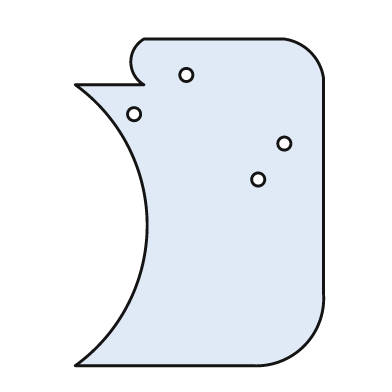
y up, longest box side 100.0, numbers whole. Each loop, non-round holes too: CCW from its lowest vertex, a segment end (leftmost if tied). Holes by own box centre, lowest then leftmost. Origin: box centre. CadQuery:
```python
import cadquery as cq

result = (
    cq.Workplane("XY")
    .moveTo(-38.0, -50.0)
    .lineTo(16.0, -50.0)
    .threePointArc((32.0, -44.0), (38.0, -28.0))
    .lineTo(38.0, 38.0)
    .threePointArc((34.0, 46.0), (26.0, 50.0))
    .lineTo(-17.0, 50.0)
    .threePointArc((-21.0, 43.0), (-17.0, 36.0))
    .lineTo(-38.0, 36.0)
    .threePointArc((-16.0, -7.0), (-38.0, -50.0))
    .close()
    .moveTo(18.0, 7.0)
    .circle(2.0)
    .moveTo(26.0, 18.0)
    .circle(2.0)
    .moveTo(-20.0, 27.0)
    .circle(2.0)
    .moveTo(-4.0, 39.0)
    .circle(2.0)
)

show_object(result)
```